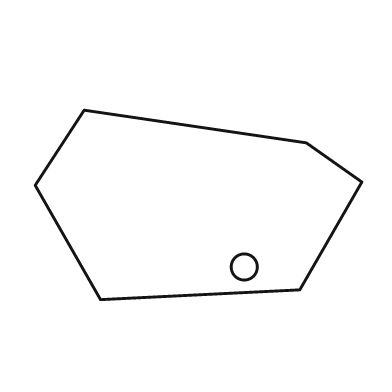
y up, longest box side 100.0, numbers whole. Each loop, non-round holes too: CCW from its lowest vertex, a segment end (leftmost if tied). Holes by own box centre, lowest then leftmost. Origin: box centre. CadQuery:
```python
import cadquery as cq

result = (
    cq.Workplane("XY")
    .moveTo(-30.0, -29.0)
    .lineTo(31.0, -26.0)
    .lineTo(50.0, 7.0)
    .lineTo(33.0, 19.0)
    .lineTo(-35.0, 29.0)
    .lineTo(-50.0, 6.0)
    .close()
    .moveTo(14.0, -19.0)
    .circle(4.0)
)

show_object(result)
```